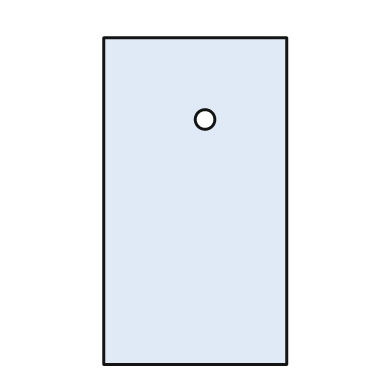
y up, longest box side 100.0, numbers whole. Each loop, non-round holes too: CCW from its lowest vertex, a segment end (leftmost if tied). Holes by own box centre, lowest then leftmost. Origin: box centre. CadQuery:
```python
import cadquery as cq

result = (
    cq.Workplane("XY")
    .moveTo(-28.0, -50.0)
    .lineTo(28.0, -50.0)
    .lineTo(28.0, 50.0)
    .lineTo(-28.0, 50.0)
    .close()
    .moveTo(3.0, 25.0)
    .circle(3.0)
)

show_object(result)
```